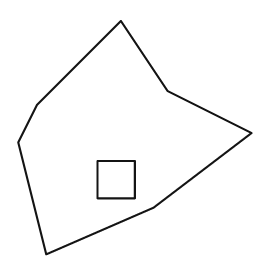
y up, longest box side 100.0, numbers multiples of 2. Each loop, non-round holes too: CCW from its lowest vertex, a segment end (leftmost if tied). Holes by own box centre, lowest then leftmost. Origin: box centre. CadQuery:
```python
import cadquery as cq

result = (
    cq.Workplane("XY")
    .moveTo(-38.0, -50.0)
    .lineTo(8.0, -30.0)
    .lineTo(50.0, 2.0)
    .lineTo(14.0, 20.0)
    .lineTo(-6.0, 50.0)
    .lineTo(-42.0, 14.0)
    .lineTo(-50.0, -2.0)
    .close()
    .moveTo(-16.0, -26.0)
    .lineTo(0.0, -26.0)
    .lineTo(0.0, -10.0)
    .lineTo(-16.0, -10.0)
    .close()
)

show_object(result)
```